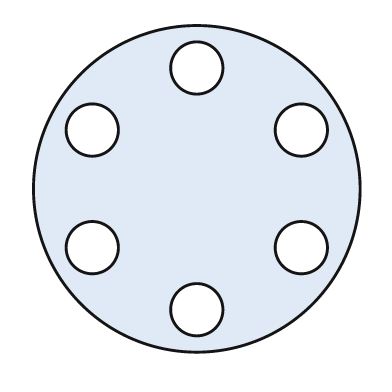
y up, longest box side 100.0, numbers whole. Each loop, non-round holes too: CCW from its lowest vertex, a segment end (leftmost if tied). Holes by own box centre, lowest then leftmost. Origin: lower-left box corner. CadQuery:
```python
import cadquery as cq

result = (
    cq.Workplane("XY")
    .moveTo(50.0, 50.0)
    .circle(50.0)
    .moveTo(50.0, 13.0)
    .circle(8.0)
    .moveTo(18.0, 32.0)
    .circle(8.0)
    .moveTo(82.0, 32.0)
    .circle(8.0)
    .moveTo(18.0, 68.0)
    .circle(8.0)
    .moveTo(82.0, 68.0)
    .circle(8.0)
    .moveTo(50.0, 87.0)
    .circle(8.0)
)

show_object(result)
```